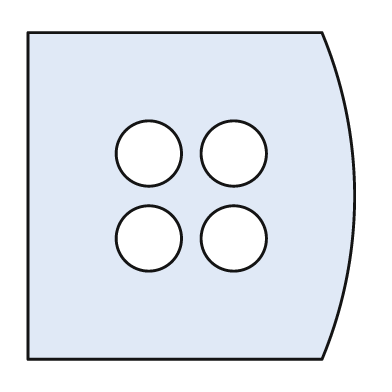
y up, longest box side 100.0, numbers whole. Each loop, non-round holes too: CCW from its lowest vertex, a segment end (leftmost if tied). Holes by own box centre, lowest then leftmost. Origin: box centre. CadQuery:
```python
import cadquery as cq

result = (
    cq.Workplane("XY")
    .moveTo(-50.0, -50.0)
    .lineTo(40.0, -50.0)
    .threePointArc((50.0, 0.0), (40.0, 50.0))
    .lineTo(-50.0, 50.0)
    .close()
    .moveTo(-13.0, -13.0)
    .circle(10.0)
    .moveTo(13.0, -13.0)
    .circle(10.0)
    .moveTo(-13.0, 13.0)
    .circle(10.0)
    .moveTo(13.0, 13.0)
    .circle(10.0)
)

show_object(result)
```